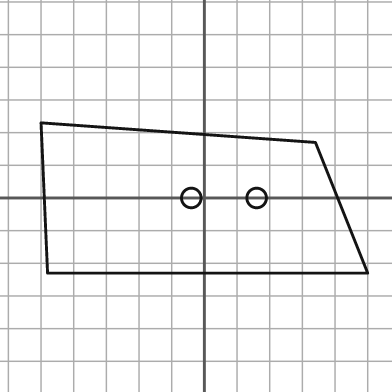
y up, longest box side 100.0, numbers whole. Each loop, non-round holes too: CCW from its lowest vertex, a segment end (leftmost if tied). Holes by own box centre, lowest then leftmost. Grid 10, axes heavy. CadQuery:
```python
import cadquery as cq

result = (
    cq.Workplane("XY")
    .moveTo(-48.0, -23.0)
    .lineTo(50.0, -23.0)
    .lineTo(34.0, 17.0)
    .lineTo(-50.0, 23.0)
    .close()
    .moveTo(-4.0, 0.0)
    .circle(3.0)
    .moveTo(16.0, 0.0)
    .circle(3.0)
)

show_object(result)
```